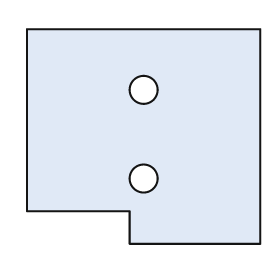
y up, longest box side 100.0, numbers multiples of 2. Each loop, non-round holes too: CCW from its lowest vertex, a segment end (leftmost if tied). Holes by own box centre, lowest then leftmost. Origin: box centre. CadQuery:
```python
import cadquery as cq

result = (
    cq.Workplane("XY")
    .moveTo(-6.0, -46.0)
    .lineTo(50.0, -46.0)
    .lineTo(50.0, 46.0)
    .lineTo(-50.0, 46.0)
    .lineTo(-50.0, -32.0)
    .lineTo(-6.0, -32.0)
    .close()
    .moveTo(0.0, -18.0)
    .circle(6.0)
    .moveTo(0.0, 20.0)
    .circle(6.0)
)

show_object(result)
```